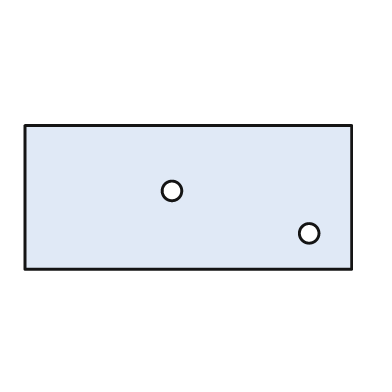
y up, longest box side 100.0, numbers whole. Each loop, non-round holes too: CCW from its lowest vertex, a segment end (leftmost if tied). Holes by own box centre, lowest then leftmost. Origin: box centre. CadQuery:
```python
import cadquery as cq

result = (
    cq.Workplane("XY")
    .moveTo(-50.0, -22.0)
    .lineTo(50.0, -22.0)
    .lineTo(50.0, 22.0)
    .lineTo(-50.0, 22.0)
    .close()
    .moveTo(37.0, -11.0)
    .circle(3.0)
    .moveTo(-5.0, 2.0)
    .circle(3.0)
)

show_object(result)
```